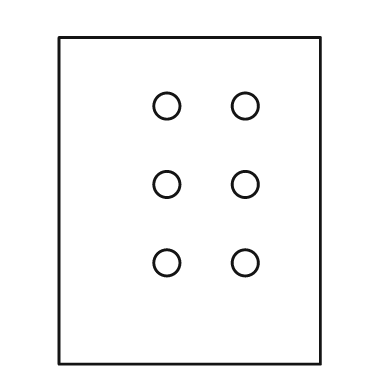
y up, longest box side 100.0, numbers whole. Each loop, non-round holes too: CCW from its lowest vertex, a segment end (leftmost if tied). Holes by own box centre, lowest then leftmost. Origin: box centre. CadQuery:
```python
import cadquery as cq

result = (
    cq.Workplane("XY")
    .moveTo(-40.0, -50.0)
    .lineTo(40.0, -50.0)
    .lineTo(40.0, 50.0)
    .lineTo(-40.0, 50.0)
    .close()
    .moveTo(-7.0, -19.0)
    .circle(4.0)
    .moveTo(17.0, -19.0)
    .circle(4.0)
    .moveTo(-7.0, 5.0)
    .circle(4.0)
    .moveTo(17.0, 5.0)
    .circle(4.0)
    .moveTo(-7.0, 29.0)
    .circle(4.0)
    .moveTo(17.0, 29.0)
    .circle(4.0)
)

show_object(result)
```